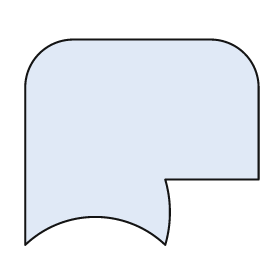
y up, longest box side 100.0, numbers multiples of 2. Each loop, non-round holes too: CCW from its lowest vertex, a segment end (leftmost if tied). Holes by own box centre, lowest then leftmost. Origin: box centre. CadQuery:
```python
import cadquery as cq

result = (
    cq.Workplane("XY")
    .moveTo(-50.0, -44.0)
    .threePointArc((-20.0, -32.0), (10.0, -44.0))
    .threePointArc((12.0, -30.0), (10.0, -16.0))
    .lineTo(50.0, -16.0)
    .lineTo(50.0, 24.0)
    .threePointArc((44.0, 38.0), (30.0, 44.0))
    .lineTo(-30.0, 44.0)
    .threePointArc((-44.0, 38.0), (-50.0, 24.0))
    .close()
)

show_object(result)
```